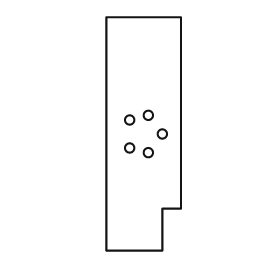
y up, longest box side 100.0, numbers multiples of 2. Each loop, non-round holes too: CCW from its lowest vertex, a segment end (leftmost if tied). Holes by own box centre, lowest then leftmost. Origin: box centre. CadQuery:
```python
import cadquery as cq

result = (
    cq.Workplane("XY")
    .moveTo(-16.0, -50.0)
    .lineTo(8.0, -50.0)
    .lineTo(8.0, -32.0)
    .lineTo(16.0, -32.0)
    .lineTo(16.0, 50.0)
    .lineTo(-16.0, 50.0)
    .close()
    .moveTo(2.0, -8.0)
    .circle(2.0)
    .moveTo(-6.0, -6.0)
    .circle(2.0)
    .moveTo(8.0, 0.0)
    .circle(2.0)
    .moveTo(-6.0, 6.0)
    .circle(2.0)
    .moveTo(2.0, 8.0)
    .circle(2.0)
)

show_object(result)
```